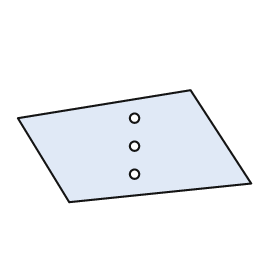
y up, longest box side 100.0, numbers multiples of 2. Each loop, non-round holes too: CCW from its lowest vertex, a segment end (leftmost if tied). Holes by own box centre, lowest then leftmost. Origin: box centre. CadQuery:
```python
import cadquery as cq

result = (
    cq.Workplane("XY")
    .moveTo(-28.0, -24.0)
    .lineTo(50.0, -16.0)
    .lineTo(24.0, 24.0)
    .lineTo(-50.0, 12.0)
    .close()
    .moveTo(0.0, -12.0)
    .circle(2.0)
    .moveTo(0.0, 0.0)
    .circle(2.0)
    .moveTo(0.0, 12.0)
    .circle(2.0)
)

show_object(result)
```